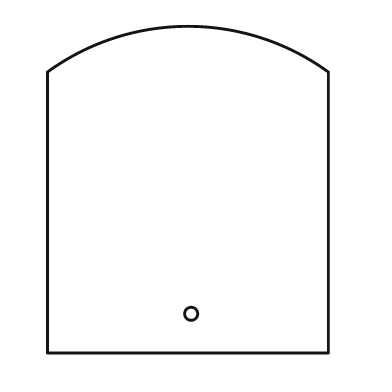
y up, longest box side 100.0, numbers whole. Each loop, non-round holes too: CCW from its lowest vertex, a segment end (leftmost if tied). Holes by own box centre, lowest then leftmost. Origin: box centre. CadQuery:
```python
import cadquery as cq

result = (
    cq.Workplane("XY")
    .moveTo(-43.0, -50.0)
    .lineTo(43.0, -50.0)
    .lineTo(43.0, 36.0)
    .threePointArc((0.0, 50.0), (-43.0, 36.0))
    .close()
    .moveTo(1.0, -38.0)
    .circle(2.0)
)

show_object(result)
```